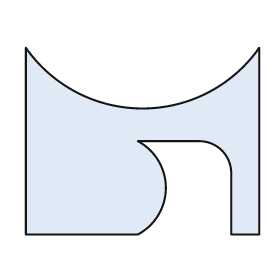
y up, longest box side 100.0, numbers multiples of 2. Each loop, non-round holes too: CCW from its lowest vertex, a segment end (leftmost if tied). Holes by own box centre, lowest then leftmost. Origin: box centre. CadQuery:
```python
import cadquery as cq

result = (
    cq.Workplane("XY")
    .moveTo(-50.0, -40.0)
    .lineTo(-2.0, -40.0)
    .threePointArc((10.0, -20.0), (-2.0, 0.0))
    .lineTo(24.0, 0.0)
    .threePointArc((34.0, -4.0), (38.0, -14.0))
    .lineTo(38.0, -40.0)
    .lineTo(50.0, -40.0)
    .lineTo(50.0, 40.0)
    .threePointArc((0.0, 14.0), (-50.0, 40.0))
    .close()
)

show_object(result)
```